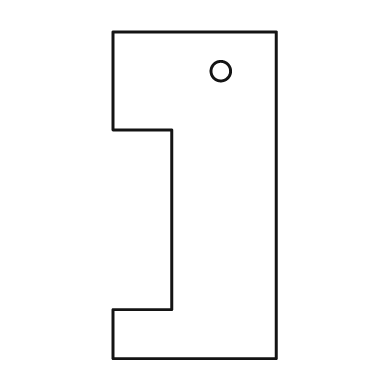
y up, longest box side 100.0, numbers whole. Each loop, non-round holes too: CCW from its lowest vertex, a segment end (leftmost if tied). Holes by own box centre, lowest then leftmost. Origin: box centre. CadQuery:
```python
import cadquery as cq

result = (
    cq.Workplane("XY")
    .moveTo(-25.0, -50.0)
    .lineTo(25.0, -50.0)
    .lineTo(25.0, 50.0)
    .lineTo(-25.0, 50.0)
    .lineTo(-25.0, 20.0)
    .lineTo(-7.0, 20.0)
    .lineTo(-7.0, -35.0)
    .lineTo(-25.0, -35.0)
    .close()
    .moveTo(8.0, 38.0)
    .circle(3.0)
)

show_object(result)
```